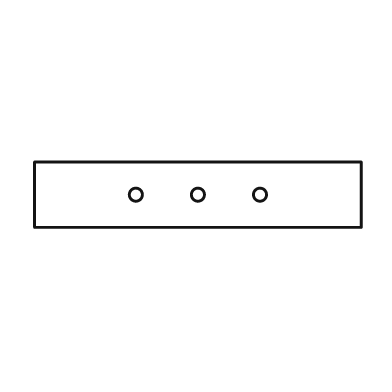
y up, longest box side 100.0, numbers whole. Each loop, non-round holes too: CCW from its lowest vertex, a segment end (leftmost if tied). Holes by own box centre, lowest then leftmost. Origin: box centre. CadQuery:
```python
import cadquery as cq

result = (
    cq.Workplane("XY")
    .moveTo(-50.0, -10.0)
    .lineTo(50.0, -10.0)
    .lineTo(50.0, 10.0)
    .lineTo(-50.0, 10.0)
    .close()
    .moveTo(-19.0, 0.0)
    .circle(2.0)
    .moveTo(0.0, 0.0)
    .circle(2.0)
    .moveTo(19.0, 0.0)
    .circle(2.0)
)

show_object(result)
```